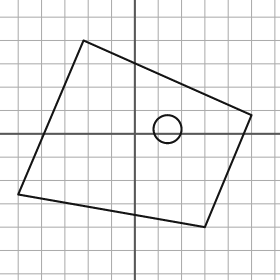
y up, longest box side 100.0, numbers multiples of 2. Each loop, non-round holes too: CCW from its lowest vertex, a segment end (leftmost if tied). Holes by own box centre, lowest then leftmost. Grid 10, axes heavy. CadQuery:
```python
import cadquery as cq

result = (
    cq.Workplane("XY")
    .moveTo(30.0, -40.0)
    .lineTo(50.0, 8.0)
    .lineTo(-22.0, 40.0)
    .lineTo(-50.0, -26.0)
    .close()
    .moveTo(14.0, 2.0)
    .circle(6.0)
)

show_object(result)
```